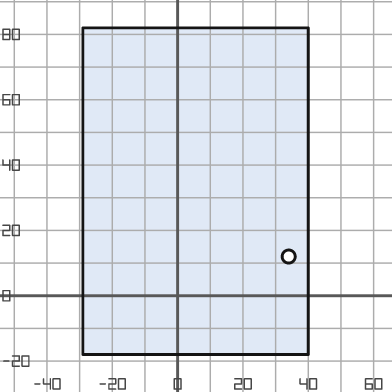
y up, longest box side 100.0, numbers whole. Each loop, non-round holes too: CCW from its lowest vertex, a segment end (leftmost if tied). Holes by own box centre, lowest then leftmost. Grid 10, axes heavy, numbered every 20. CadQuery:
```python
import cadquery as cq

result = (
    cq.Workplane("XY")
    .moveTo(-29.0, -18.0)
    .lineTo(40.0, -18.0)
    .lineTo(40.0, 82.0)
    .lineTo(-29.0, 82.0)
    .close()
    .moveTo(34.0, 12.0)
    .circle(2.0)
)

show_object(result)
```